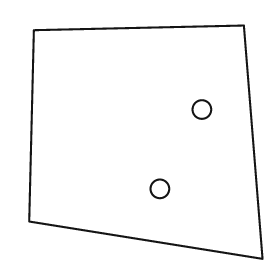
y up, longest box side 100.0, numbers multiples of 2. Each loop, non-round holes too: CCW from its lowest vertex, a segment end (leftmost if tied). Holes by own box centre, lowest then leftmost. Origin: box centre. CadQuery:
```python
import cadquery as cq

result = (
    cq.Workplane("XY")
    .moveTo(50.0, -50.0)
    .lineTo(42.0, 50.0)
    .lineTo(-48.0, 48.0)
    .lineTo(-50.0, -34.0)
    .close()
    .moveTo(6.0, -20.0)
    .circle(4.0)
    .moveTo(24.0, 14.0)
    .circle(4.0)
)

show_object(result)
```